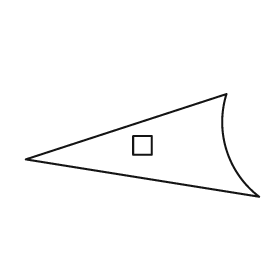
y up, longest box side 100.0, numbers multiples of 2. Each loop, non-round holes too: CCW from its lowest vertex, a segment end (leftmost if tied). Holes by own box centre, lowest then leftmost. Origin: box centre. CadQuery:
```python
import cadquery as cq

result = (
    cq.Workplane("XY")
    .moveTo(50.0, -22.0)
    .threePointArc((36.0, -2.0), (36.0, 22.0))
    .lineTo(-50.0, -6.0)
    .close()
    .moveTo(-4.0, -4.0)
    .lineTo(4.0, -4.0)
    .lineTo(4.0, 4.0)
    .lineTo(-4.0, 4.0)
    .close()
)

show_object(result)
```